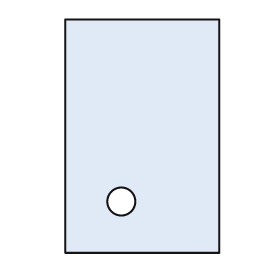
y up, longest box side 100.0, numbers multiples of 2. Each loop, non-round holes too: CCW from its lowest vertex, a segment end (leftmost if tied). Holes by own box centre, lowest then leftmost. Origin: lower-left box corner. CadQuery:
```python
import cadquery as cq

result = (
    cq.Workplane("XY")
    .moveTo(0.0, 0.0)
    .lineTo(66.0, 0.0)
    .lineTo(66.0, 100.0)
    .lineTo(0.0, 100.0)
    .close()
    .moveTo(24.0, 22.0)
    .circle(6.0)
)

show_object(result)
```